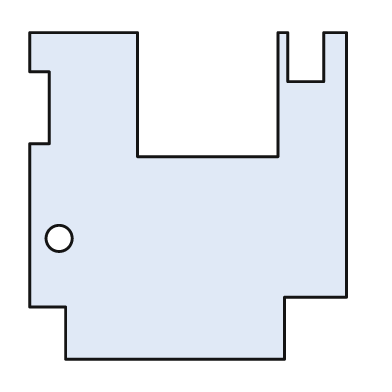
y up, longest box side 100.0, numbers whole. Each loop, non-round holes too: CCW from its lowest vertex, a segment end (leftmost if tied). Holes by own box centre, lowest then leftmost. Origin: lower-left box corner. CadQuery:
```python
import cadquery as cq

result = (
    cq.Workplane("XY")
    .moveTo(11.0, 0.0)
    .lineTo(78.0, 0.0)
    .lineTo(78.0, 19.0)
    .lineTo(97.0, 19.0)
    .lineTo(97.0, 100.0)
    .lineTo(90.0, 100.0)
    .lineTo(90.0, 85.0)
    .lineTo(79.0, 85.0)
    .lineTo(79.0, 100.0)
    .lineTo(76.0, 100.0)
    .lineTo(76.0, 62.0)
    .lineTo(33.0, 62.0)
    .lineTo(33.0, 100.0)
    .lineTo(0.0, 100.0)
    .lineTo(0.0, 88.0)
    .lineTo(6.0, 88.0)
    .lineTo(6.0, 66.0)
    .lineTo(0.0, 66.0)
    .lineTo(0.0, 16.0)
    .lineTo(11.0, 16.0)
    .close()
    .moveTo(9.0, 37.0)
    .circle(4.0)
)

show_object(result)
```